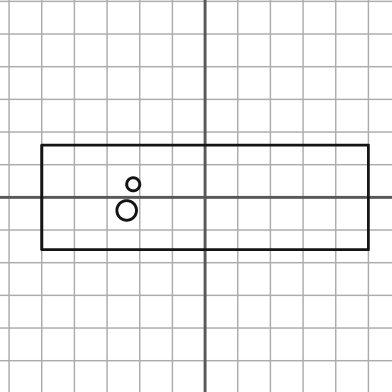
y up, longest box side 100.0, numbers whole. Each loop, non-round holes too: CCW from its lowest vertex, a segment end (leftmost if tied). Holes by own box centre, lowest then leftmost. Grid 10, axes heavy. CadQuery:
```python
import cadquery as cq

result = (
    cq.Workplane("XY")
    .moveTo(-50.0, -16.0)
    .lineTo(50.0, -16.0)
    .lineTo(50.0, 16.0)
    .lineTo(-50.0, 16.0)
    .close()
    .moveTo(-24.0, -4.0)
    .circle(3.0)
    .moveTo(-22.0, 4.0)
    .circle(2.0)
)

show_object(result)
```